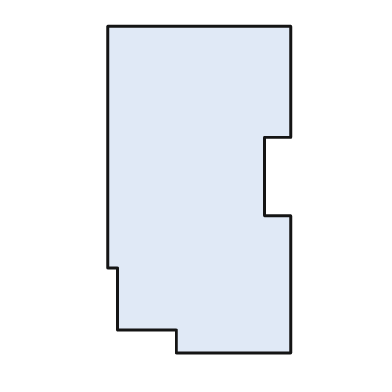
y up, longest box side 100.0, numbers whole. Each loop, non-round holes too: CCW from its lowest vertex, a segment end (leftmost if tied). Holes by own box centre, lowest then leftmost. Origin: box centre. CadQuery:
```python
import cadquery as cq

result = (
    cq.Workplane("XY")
    .moveTo(-7.0, -50.0)
    .lineTo(28.0, -50.0)
    .lineTo(28.0, -8.0)
    .lineTo(20.0, -8.0)
    .lineTo(20.0, 16.0)
    .lineTo(28.0, 16.0)
    .lineTo(28.0, 50.0)
    .lineTo(-28.0, 50.0)
    .lineTo(-28.0, -24.0)
    .lineTo(-25.0, -24.0)
    .lineTo(-25.0, -43.0)
    .lineTo(-7.0, -43.0)
    .close()
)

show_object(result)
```